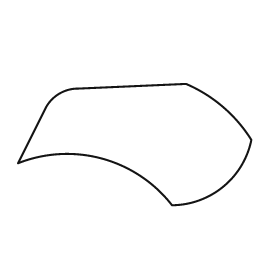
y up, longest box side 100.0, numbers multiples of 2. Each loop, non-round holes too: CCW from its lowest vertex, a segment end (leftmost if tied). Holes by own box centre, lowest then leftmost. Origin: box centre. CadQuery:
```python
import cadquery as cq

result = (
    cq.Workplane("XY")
    .moveTo(16.0, -26.0)
    .threePointArc((38.0, -18.0), (50.0, 2.0))
    .threePointArc((38.0, 16.0), (22.0, 26.0))
    .lineTo(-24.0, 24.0)
    .threePointArc((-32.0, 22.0), (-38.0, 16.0))
    .lineTo(-50.0, -8.0)
    .threePointArc((-14.0, -6.0), (16.0, -26.0))
    .close()
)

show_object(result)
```